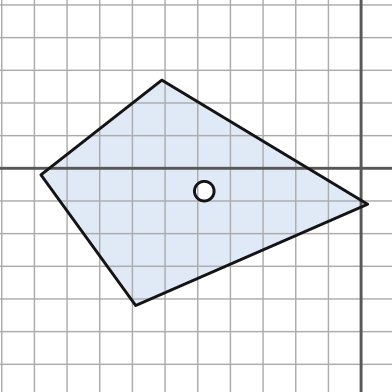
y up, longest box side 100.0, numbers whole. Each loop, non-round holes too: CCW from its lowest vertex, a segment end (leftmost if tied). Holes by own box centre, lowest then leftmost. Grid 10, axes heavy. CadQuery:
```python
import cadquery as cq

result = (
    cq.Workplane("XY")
    .moveTo(-69.0, -42.0)
    .lineTo(2.0, -11.0)
    .lineTo(-61.0, 27.0)
    .lineTo(-98.0, -2.0)
    .close()
    .moveTo(-48.0, -7.0)
    .circle(3.0)
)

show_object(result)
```